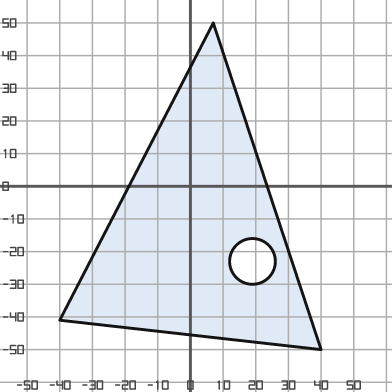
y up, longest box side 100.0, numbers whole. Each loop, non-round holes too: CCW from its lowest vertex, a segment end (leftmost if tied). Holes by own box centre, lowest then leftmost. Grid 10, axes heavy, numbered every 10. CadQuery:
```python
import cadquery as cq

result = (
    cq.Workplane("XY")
    .moveTo(40.0, -50.0)
    .lineTo(7.0, 50.0)
    .lineTo(-40.0, -41.0)
    .close()
    .moveTo(19.0, -23.0)
    .circle(7.0)
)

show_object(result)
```